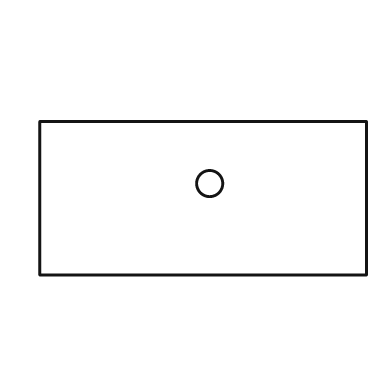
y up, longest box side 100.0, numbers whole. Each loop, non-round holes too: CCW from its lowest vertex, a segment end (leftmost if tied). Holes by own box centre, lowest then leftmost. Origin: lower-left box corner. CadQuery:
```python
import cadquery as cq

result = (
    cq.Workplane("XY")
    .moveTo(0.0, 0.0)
    .lineTo(100.0, 0.0)
    .lineTo(100.0, 47.0)
    .lineTo(0.0, 47.0)
    .close()
    .moveTo(52.0, 28.0)
    .circle(4.0)
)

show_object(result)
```